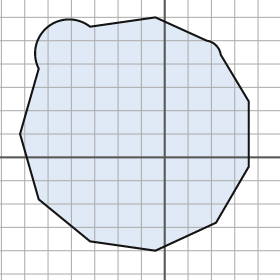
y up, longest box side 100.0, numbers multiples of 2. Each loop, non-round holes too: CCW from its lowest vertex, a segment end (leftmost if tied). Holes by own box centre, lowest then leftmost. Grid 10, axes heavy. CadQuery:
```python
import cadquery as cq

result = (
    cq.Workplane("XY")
    .moveTo(-4.0, -40.0)
    .lineTo(22.0, -28.0)
    .lineTo(36.0, -4.0)
    .lineTo(36.0, 24.0)
    .lineTo(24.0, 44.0)
    .threePointArc((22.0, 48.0), (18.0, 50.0))
    .lineTo(-4.0, 60.0)
    .lineTo(-32.0, 56.0)
    .threePointArc((-50.0, 56.0), (-54.0, 38.0))
    .lineTo(-62.0, 10.0)
    .lineTo(-54.0, -18.0)
    .lineTo(-32.0, -36.0)
    .close()
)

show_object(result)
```